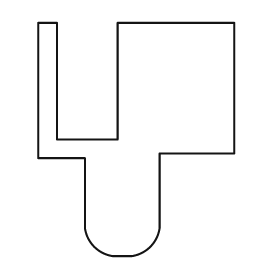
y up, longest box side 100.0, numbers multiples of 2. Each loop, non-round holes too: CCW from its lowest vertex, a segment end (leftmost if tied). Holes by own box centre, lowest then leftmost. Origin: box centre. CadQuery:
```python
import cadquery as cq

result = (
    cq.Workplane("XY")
    .moveTo(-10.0, -50.0)
    .lineTo(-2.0, -50.0)
    .threePointArc((6.0, -46.0), (10.0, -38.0))
    .lineTo(10.0, -6.0)
    .lineTo(42.0, -6.0)
    .lineTo(42.0, 50.0)
    .lineTo(-8.0, 50.0)
    .lineTo(-8.0, 0.0)
    .lineTo(-34.0, 0.0)
    .lineTo(-34.0, 50.0)
    .lineTo(-42.0, 50.0)
    .lineTo(-42.0, -8.0)
    .lineTo(-22.0, -8.0)
    .lineTo(-22.0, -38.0)
    .threePointArc((-18.0, -46.0), (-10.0, -50.0))
    .close()
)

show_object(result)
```